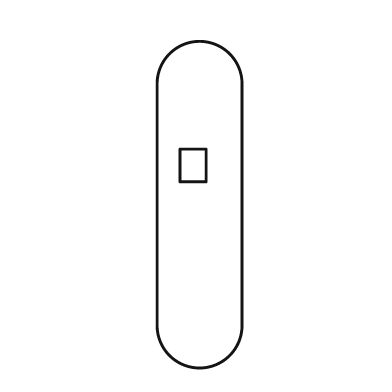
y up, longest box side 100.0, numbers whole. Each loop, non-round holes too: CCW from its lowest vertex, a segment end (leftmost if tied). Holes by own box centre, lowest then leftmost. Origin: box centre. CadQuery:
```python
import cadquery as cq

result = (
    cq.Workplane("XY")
    .moveTo(-13.0, -37.0)
    .threePointArc((0.0, -50.0), (13.0, -37.0))
    .lineTo(13.0, 37.0)
    .threePointArc((0.0, 50.0), (-13.0, 37.0))
    .close()
    .moveTo(-6.0, 7.0)
    .lineTo(2.0, 7.0)
    .lineTo(2.0, 17.0)
    .lineTo(-6.0, 17.0)
    .close()
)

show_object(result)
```